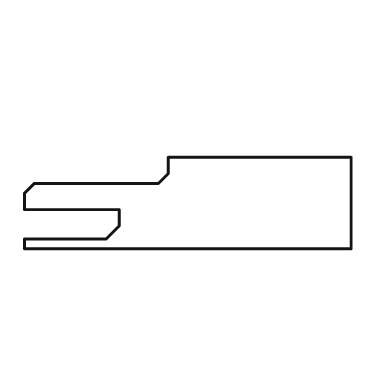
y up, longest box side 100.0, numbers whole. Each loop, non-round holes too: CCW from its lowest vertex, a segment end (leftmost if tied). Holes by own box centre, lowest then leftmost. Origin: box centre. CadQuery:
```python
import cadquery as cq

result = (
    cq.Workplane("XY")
    .moveTo(-50.0, -14.0)
    .lineTo(50.0, -14.0)
    .lineTo(50.0, 14.0)
    .lineTo(-6.0, 14.0)
    .lineTo(-6.0, 9.0)
    .lineTo(-9.0, 6.0)
    .lineTo(-47.0, 6.0)
    .lineTo(-50.0, 3.0)
    .lineTo(-50.0, -2.0)
    .lineTo(-21.0, -2.0)
    .lineTo(-21.0, -7.0)
    .lineTo(-25.0, -11.0)
    .lineTo(-50.0, -11.0)
    .close()
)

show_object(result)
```